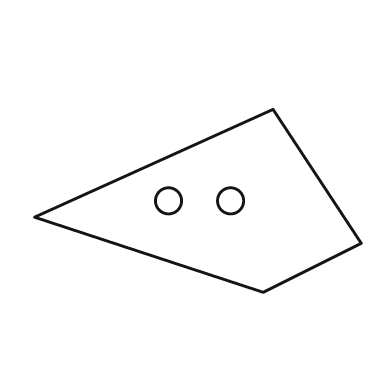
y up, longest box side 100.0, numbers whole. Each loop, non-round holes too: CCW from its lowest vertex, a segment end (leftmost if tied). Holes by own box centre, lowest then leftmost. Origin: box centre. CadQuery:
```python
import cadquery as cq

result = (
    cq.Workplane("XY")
    .moveTo(20.0, -28.0)
    .lineTo(50.0, -13.0)
    .lineTo(23.0, 28.0)
    .lineTo(-50.0, -5.0)
    .close()
    .moveTo(-9.0, 0.0)
    .circle(4.0)
    .moveTo(10.0, 0.0)
    .circle(4.0)
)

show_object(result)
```